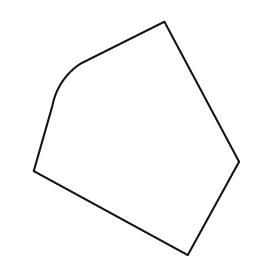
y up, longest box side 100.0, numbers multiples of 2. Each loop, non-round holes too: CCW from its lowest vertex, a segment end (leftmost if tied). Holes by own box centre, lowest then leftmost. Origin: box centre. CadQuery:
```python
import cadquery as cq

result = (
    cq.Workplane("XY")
    .moveTo(22.0, -50.0)
    .lineTo(44.0, -10.0)
    .lineTo(12.0, 50.0)
    .lineTo(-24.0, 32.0)
    .threePointArc((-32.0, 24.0), (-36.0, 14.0))
    .lineTo(-44.0, -14.0)
    .close()
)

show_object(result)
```